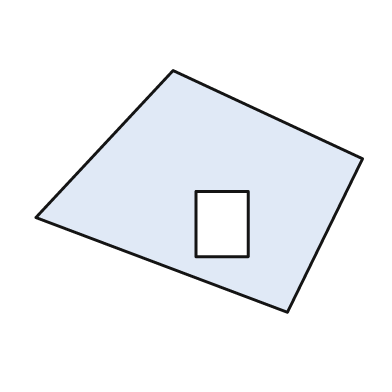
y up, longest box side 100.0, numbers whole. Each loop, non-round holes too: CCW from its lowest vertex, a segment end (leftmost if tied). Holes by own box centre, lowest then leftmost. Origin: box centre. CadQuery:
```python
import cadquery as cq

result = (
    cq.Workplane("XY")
    .moveTo(27.0, -37.0)
    .lineTo(50.0, 10.0)
    .lineTo(-8.0, 37.0)
    .lineTo(-50.0, -8.0)
    .close()
    .moveTo(-1.0, -20.0)
    .lineTo(15.0, -20.0)
    .lineTo(15.0, 0.0)
    .lineTo(-1.0, 0.0)
    .close()
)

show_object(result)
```